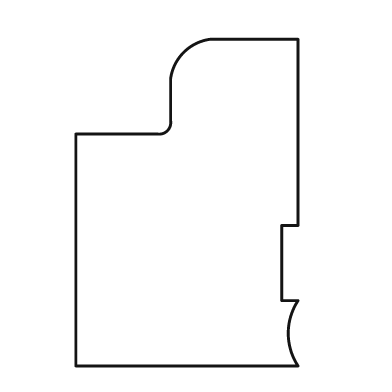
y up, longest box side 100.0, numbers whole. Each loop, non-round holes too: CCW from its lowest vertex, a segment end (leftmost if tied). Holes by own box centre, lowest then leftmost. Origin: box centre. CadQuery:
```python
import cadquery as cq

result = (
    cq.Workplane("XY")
    .moveTo(-34.0, -50.0)
    .lineTo(34.0, -50.0)
    .threePointArc((31.0, -40.0), (34.0, -30.0))
    .lineTo(29.0, -30.0)
    .lineTo(29.0, -7.0)
    .lineTo(34.0, -7.0)
    .lineTo(34.0, 50.0)
    .lineTo(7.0, 50.0)
    .threePointArc((-1.0, 46.0), (-5.0, 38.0))
    .lineTo(-5.0, 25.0)
    .threePointArc((-6.0, 22.0), (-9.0, 21.0))
    .lineTo(-34.0, 21.0)
    .close()
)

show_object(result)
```